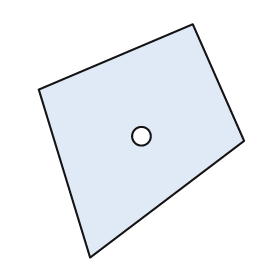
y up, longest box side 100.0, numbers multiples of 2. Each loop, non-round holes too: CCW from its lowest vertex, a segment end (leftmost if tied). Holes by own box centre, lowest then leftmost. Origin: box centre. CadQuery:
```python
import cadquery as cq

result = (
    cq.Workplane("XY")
    .moveTo(-22.0, -50.0)
    .lineTo(44.0, 0.0)
    .lineTo(22.0, 50.0)
    .lineTo(-44.0, 22.0)
    .close()
    .moveTo(0.0, 2.0)
    .circle(4.0)
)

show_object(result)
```